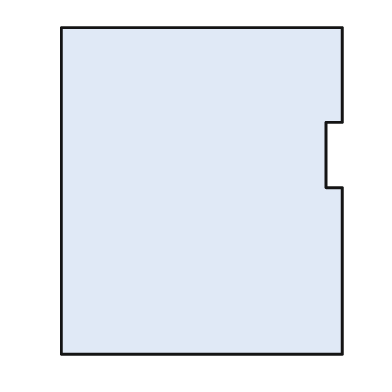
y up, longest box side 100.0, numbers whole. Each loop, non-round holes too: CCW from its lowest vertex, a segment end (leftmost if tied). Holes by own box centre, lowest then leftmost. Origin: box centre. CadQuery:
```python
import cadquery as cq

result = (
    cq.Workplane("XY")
    .moveTo(-43.0, -50.0)
    .lineTo(43.0, -50.0)
    .lineTo(43.0, 1.0)
    .lineTo(38.0, 1.0)
    .lineTo(38.0, 21.0)
    .lineTo(43.0, 21.0)
    .lineTo(43.0, 50.0)
    .lineTo(-43.0, 50.0)
    .close()
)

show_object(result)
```